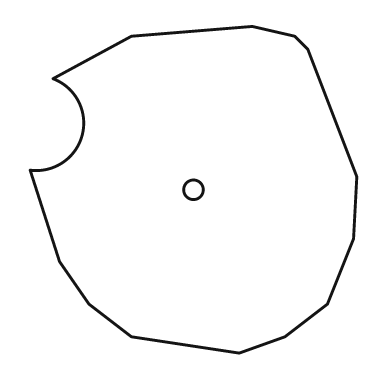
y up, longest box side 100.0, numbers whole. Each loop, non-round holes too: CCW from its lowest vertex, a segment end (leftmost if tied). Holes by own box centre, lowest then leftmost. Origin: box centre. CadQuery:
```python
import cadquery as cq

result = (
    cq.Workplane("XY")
    .moveTo(14.0, -50.0)
    .lineTo(28.0, -45.0)
    .lineTo(41.0, -35.0)
    .lineTo(49.0, -15.0)
    .lineTo(50.0, 4.0)
    .lineTo(35.0, 43.0)
    .lineTo(31.0, 47.0)
    .lineTo(18.0, 50.0)
    .lineTo(-19.0, 47.0)
    .lineTo(-43.0, 34.0)
    .threePointArc((-34.0, 17.0), (-50.0, 6.0))
    .lineTo(-41.0, -22.0)
    .lineTo(-32.0, -35.0)
    .lineTo(-19.0, -45.0)
    .close()
    .moveTo(0.0, 0.0)
    .circle(3.0)
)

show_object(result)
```